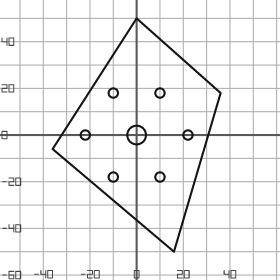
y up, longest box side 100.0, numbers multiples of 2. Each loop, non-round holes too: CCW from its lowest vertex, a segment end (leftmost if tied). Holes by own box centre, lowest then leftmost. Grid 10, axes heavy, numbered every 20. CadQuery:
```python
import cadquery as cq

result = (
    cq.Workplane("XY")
    .moveTo(16.0, -50.0)
    .lineTo(36.0, 18.0)
    .lineTo(0.0, 50.0)
    .lineTo(-36.0, -6.0)
    .close()
    .moveTo(-10.0, -18.0)
    .circle(2.0)
    .moveTo(10.0, -18.0)
    .circle(2.0)
    .moveTo(-22.0, 0.0)
    .circle(2.0)
    .moveTo(0.0, 0.0)
    .circle(4.0)
    .moveTo(22.0, 0.0)
    .circle(2.0)
    .moveTo(-10.0, 18.0)
    .circle(2.0)
    .moveTo(10.0, 18.0)
    .circle(2.0)
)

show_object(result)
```